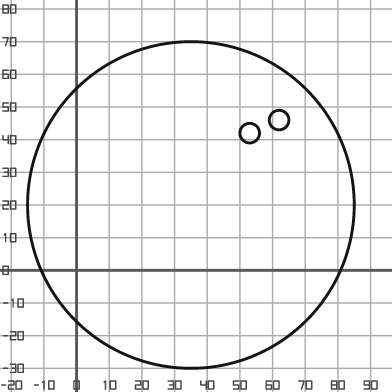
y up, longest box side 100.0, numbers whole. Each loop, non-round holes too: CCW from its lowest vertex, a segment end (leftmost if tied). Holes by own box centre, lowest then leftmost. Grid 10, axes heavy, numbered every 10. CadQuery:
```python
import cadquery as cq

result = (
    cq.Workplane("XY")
    .moveTo(35.0, 20.0)
    .circle(50.0)
    .moveTo(53.0, 42.0)
    .circle(3.0)
    .moveTo(62.0, 46.0)
    .circle(3.0)
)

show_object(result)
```